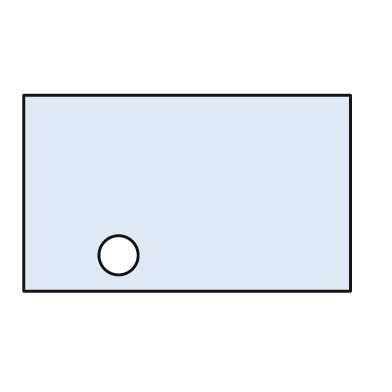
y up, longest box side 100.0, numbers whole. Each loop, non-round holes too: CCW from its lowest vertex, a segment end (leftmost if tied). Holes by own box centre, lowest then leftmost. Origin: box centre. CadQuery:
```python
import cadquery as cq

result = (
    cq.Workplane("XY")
    .moveTo(-50.0, -30.0)
    .lineTo(50.0, -30.0)
    .lineTo(50.0, 30.0)
    .lineTo(-50.0, 30.0)
    .close()
    .moveTo(-21.0, -19.0)
    .circle(6.0)
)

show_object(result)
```